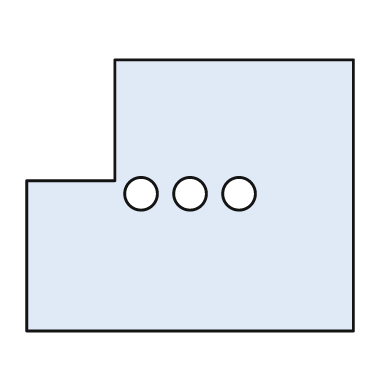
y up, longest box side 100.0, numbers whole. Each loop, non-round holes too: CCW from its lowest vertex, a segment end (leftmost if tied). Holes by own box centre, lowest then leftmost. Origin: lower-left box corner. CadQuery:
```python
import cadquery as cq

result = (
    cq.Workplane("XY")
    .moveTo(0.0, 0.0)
    .lineTo(100.0, 0.0)
    .lineTo(100.0, 83.0)
    .lineTo(27.0, 83.0)
    .lineTo(27.0, 46.0)
    .lineTo(0.0, 46.0)
    .close()
    .moveTo(35.0, 42.0)
    .circle(5.0)
    .moveTo(50.0, 42.0)
    .circle(5.0)
    .moveTo(65.0, 42.0)
    .circle(5.0)
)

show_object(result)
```